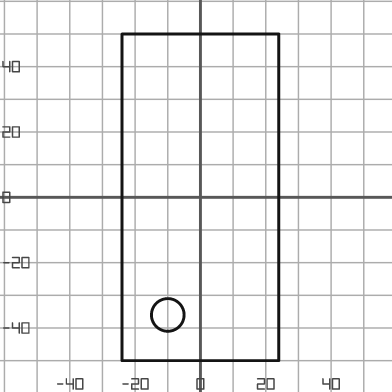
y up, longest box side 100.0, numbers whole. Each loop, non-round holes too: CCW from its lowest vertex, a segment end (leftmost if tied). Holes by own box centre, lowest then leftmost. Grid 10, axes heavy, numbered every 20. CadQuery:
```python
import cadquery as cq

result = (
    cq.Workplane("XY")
    .moveTo(-24.0, -50.0)
    .lineTo(24.0, -50.0)
    .lineTo(24.0, 50.0)
    .lineTo(-24.0, 50.0)
    .close()
    .moveTo(-10.0, -36.0)
    .circle(5.0)
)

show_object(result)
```